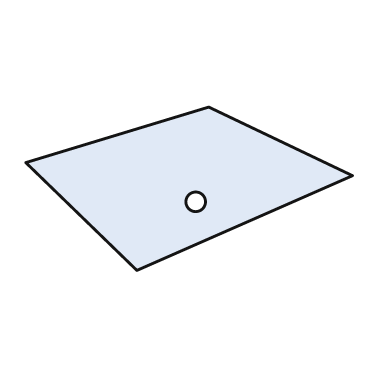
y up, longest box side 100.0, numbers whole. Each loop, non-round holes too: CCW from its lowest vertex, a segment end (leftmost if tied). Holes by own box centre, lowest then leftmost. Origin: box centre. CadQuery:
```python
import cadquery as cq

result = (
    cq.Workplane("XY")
    .moveTo(-16.0, -25.0)
    .lineTo(50.0, 4.0)
    .lineTo(6.0, 25.0)
    .lineTo(-50.0, 8.0)
    .close()
    .moveTo(2.0, -4.0)
    .circle(3.0)
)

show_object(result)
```